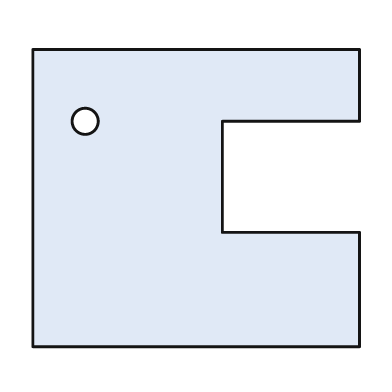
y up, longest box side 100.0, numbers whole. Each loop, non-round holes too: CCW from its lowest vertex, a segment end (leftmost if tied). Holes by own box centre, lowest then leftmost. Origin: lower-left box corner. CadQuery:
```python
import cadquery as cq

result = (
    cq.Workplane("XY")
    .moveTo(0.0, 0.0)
    .lineTo(100.0, 0.0)
    .lineTo(100.0, 35.0)
    .lineTo(58.0, 35.0)
    .lineTo(58.0, 69.0)
    .lineTo(100.0, 69.0)
    .lineTo(100.0, 91.0)
    .lineTo(0.0, 91.0)
    .close()
    .moveTo(16.0, 69.0)
    .circle(4.0)
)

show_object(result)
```